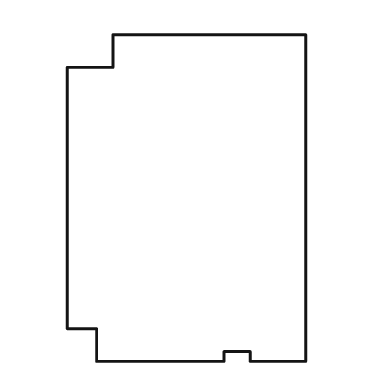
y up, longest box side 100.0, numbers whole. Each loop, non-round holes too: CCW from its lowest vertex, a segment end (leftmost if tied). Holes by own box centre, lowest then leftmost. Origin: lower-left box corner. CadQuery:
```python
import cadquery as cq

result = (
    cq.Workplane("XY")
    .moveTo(9.0, 0.0)
    .lineTo(48.0, 0.0)
    .lineTo(48.0, 3.0)
    .lineTo(56.0, 3.0)
    .lineTo(56.0, 0.0)
    .lineTo(73.0, 0.0)
    .lineTo(73.0, 100.0)
    .lineTo(14.0, 100.0)
    .lineTo(14.0, 90.0)
    .lineTo(0.0, 90.0)
    .lineTo(0.0, 10.0)
    .lineTo(9.0, 10.0)
    .close()
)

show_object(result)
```